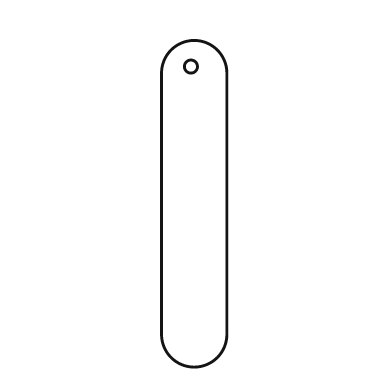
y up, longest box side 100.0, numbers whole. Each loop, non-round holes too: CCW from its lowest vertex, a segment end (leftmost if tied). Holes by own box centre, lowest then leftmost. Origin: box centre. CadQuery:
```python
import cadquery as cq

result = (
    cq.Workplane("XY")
    .moveTo(-10.0, -40.0)
    .threePointArc((0.0, -50.0), (10.0, -40.0))
    .lineTo(10.0, 40.0)
    .threePointArc((0.0, 50.0), (-10.0, 40.0))
    .close()
    .moveTo(-1.0, 42.0)
    .circle(2.0)
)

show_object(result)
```